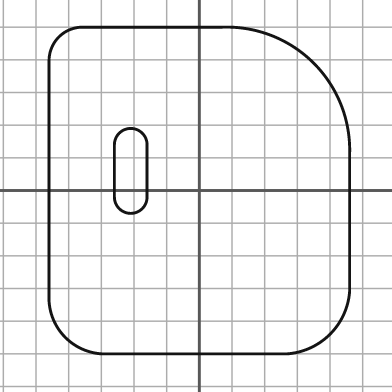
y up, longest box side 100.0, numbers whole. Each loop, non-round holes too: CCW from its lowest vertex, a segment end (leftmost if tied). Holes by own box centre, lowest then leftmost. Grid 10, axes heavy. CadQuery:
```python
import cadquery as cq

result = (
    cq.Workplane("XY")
    .moveTo(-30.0, -50.0)
    .lineTo(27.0, -50.0)
    .threePointArc((40.0, -44.0), (46.0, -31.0))
    .lineTo(46.0, 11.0)
    .threePointArc((35.0, 39.0), (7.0, 50.0))
    .lineTo(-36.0, 50.0)
    .threePointArc((-43.0, 47.0), (-46.0, 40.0))
    .lineTo(-46.0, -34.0)
    .threePointArc((-41.0, -45.0), (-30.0, -50.0))
    .close()
    .moveTo(-26.0, -2.0)
    .threePointArc((-21.0, -7.0), (-16.0, -2.0))
    .lineTo(-16.0, 14.0)
    .threePointArc((-21.0, 19.0), (-26.0, 14.0))
    .close()
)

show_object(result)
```